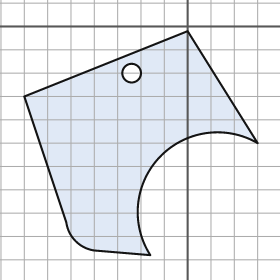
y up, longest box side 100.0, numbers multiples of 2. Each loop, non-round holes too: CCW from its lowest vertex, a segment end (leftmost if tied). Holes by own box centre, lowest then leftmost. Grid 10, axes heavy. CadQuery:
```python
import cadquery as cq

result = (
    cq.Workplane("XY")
    .moveTo(-16.0, -98.0)
    .threePointArc((-12.0, -56.0), (30.0, -50.0))
    .lineTo(0.0, -2.0)
    .lineTo(-70.0, -30.0)
    .lineTo(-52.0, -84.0)
    .threePointArc((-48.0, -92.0), (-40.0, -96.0))
    .close()
    .moveTo(-24.0, -20.0)
    .circle(4.0)
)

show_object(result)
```